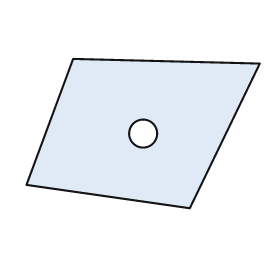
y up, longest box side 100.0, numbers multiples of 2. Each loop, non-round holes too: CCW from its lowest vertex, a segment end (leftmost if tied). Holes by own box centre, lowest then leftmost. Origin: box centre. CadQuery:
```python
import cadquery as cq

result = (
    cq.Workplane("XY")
    .moveTo(20.0, -32.0)
    .lineTo(50.0, 30.0)
    .lineTo(-30.0, 32.0)
    .lineTo(-50.0, -22.0)
    .close()
    .moveTo(0.0, 0.0)
    .circle(6.0)
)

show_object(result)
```